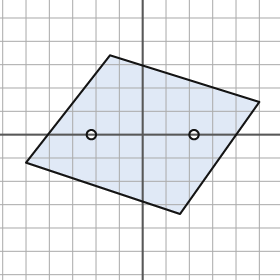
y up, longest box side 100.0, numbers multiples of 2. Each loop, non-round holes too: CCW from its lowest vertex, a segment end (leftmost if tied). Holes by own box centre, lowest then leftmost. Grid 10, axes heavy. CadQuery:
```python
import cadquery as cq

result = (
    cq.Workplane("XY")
    .moveTo(16.0, -34.0)
    .lineTo(50.0, 14.0)
    .lineTo(-14.0, 34.0)
    .lineTo(-50.0, -12.0)
    .close()
    .moveTo(-22.0, 0.0)
    .circle(2.0)
    .moveTo(22.0, 0.0)
    .circle(2.0)
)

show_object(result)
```